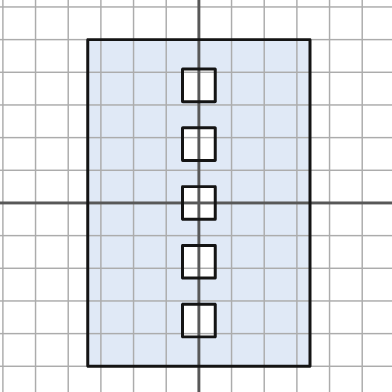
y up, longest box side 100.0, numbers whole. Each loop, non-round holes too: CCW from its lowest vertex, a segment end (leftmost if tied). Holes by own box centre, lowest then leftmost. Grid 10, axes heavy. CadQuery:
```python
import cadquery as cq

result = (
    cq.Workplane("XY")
    .moveTo(-34.0, -50.0)
    .lineTo(34.0, -50.0)
    .lineTo(34.0, 50.0)
    .lineTo(-34.0, 50.0)
    .close()
    .moveTo(-5.0, -41.0)
    .lineTo(5.0, -41.0)
    .lineTo(5.0, -31.0)
    .lineTo(-5.0, -31.0)
    .close()
    .moveTo(-5.0, -23.0)
    .lineTo(5.0, -23.0)
    .lineTo(5.0, -13.0)
    .lineTo(-5.0, -13.0)
    .close()
    .moveTo(-5.0, -5.0)
    .lineTo(5.0, -5.0)
    .lineTo(5.0, 5.0)
    .lineTo(-5.0, 5.0)
    .close()
    .moveTo(-5.0, 13.0)
    .lineTo(5.0, 13.0)
    .lineTo(5.0, 23.0)
    .lineTo(-5.0, 23.0)
    .close()
    .moveTo(-5.0, 31.0)
    .lineTo(5.0, 31.0)
    .lineTo(5.0, 41.0)
    .lineTo(-5.0, 41.0)
    .close()
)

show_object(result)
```